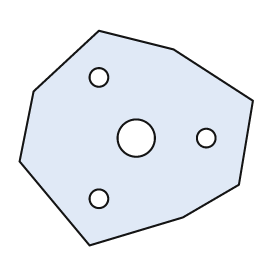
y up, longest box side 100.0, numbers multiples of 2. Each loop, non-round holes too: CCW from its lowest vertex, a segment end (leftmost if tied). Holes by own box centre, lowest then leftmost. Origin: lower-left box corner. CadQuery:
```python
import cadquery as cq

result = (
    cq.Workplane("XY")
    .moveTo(30.0, 0.0)
    .lineTo(70.0, 12.0)
    .lineTo(94.0, 26.0)
    .lineTo(100.0, 62.0)
    .lineTo(66.0, 84.0)
    .lineTo(34.0, 92.0)
    .lineTo(6.0, 66.0)
    .lineTo(0.0, 36.0)
    .close()
    .moveTo(34.0, 20.0)
    .circle(4.0)
    .moveTo(50.0, 46.0)
    .circle(8.0)
    .moveTo(80.0, 46.0)
    .circle(4.0)
    .moveTo(34.0, 72.0)
    .circle(4.0)
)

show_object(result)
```